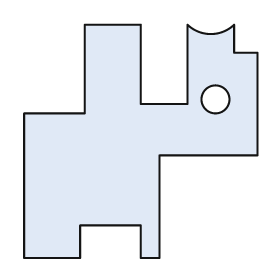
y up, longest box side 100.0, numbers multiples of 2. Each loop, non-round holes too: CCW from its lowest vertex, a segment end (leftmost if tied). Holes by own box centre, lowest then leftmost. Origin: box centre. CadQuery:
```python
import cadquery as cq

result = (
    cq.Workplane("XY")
    .moveTo(-50.0, -50.0)
    .lineTo(-26.0, -50.0)
    .lineTo(-26.0, -36.0)
    .lineTo(0.0, -36.0)
    .lineTo(0.0, -50.0)
    .lineTo(8.0, -50.0)
    .lineTo(8.0, -6.0)
    .lineTo(50.0, -6.0)
    .lineTo(50.0, 38.0)
    .lineTo(40.0, 38.0)
    .lineTo(40.0, 50.0)
    .threePointArc((30.0, 46.0), (20.0, 50.0))
    .lineTo(20.0, 16.0)
    .lineTo(0.0, 16.0)
    .lineTo(0.0, 50.0)
    .lineTo(-24.0, 50.0)
    .lineTo(-24.0, 12.0)
    .lineTo(-50.0, 12.0)
    .close()
    .moveTo(32.0, 18.0)
    .circle(6.0)
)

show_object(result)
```